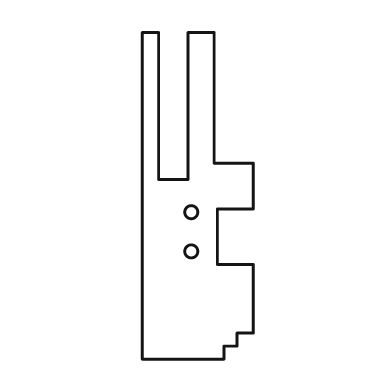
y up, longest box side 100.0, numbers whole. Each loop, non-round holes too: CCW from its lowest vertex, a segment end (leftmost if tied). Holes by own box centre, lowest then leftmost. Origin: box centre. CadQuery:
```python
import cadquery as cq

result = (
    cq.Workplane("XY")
    .moveTo(-17.0, -50.0)
    .lineTo(8.0, -50.0)
    .lineTo(8.0, -46.0)
    .lineTo(12.0, -46.0)
    .lineTo(12.0, -42.0)
    .lineTo(17.0, -42.0)
    .lineTo(17.0, -21.0)
    .lineTo(6.0, -21.0)
    .lineTo(6.0, -4.0)
    .lineTo(17.0, -4.0)
    .lineTo(17.0, 10.0)
    .lineTo(5.0, 10.0)
    .lineTo(5.0, 50.0)
    .lineTo(-3.0, 50.0)
    .lineTo(-3.0, 5.0)
    .lineTo(-12.0, 5.0)
    .lineTo(-12.0, 50.0)
    .lineTo(-17.0, 50.0)
    .close()
    .moveTo(-2.0, -17.0)
    .circle(2.0)
    .moveTo(-2.0, -5.0)
    .circle(2.0)
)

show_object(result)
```